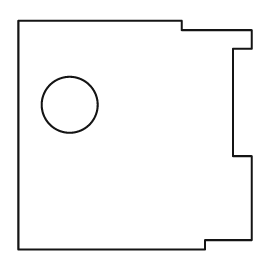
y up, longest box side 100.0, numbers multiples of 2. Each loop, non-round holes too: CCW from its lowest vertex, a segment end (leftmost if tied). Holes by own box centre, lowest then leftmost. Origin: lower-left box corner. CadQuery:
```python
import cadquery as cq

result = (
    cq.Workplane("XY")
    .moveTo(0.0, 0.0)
    .lineTo(80.0, 0.0)
    .lineTo(80.0, 4.0)
    .lineTo(100.0, 4.0)
    .lineTo(100.0, 40.0)
    .lineTo(92.0, 40.0)
    .lineTo(92.0, 86.0)
    .lineTo(100.0, 86.0)
    .lineTo(100.0, 94.0)
    .lineTo(70.0, 94.0)
    .lineTo(70.0, 98.0)
    .lineTo(0.0, 98.0)
    .close()
    .moveTo(22.0, 62.0)
    .circle(12.0)
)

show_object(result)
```